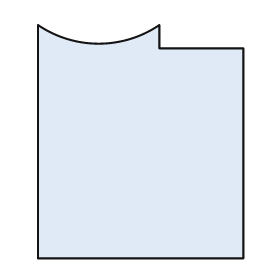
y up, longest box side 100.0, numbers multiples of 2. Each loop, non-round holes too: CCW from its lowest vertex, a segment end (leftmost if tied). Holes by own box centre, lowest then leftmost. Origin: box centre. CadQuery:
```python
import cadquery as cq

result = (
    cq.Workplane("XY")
    .moveTo(-44.0, -50.0)
    .lineTo(44.0, -50.0)
    .lineTo(44.0, 40.0)
    .lineTo(8.0, 40.0)
    .lineTo(8.0, 50.0)
    .threePointArc((-18.0, 42.0), (-44.0, 50.0))
    .close()
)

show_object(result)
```